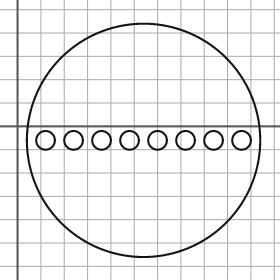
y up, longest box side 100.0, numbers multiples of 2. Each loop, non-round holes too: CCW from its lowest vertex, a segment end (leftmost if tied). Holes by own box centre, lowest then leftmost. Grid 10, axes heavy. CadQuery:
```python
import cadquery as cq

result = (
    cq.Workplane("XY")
    .moveTo(54.0, -6.0)
    .circle(50.0)
    .moveTo(12.0, -6.0)
    .circle(4.0)
    .moveTo(24.0, -6.0)
    .circle(4.0)
    .moveTo(36.0, -6.0)
    .circle(4.0)
    .moveTo(48.0, -6.0)
    .circle(4.0)
    .moveTo(60.0, -6.0)
    .circle(4.0)
    .moveTo(72.0, -6.0)
    .circle(4.0)
    .moveTo(84.0, -6.0)
    .circle(4.0)
    .moveTo(96.0, -6.0)
    .circle(4.0)
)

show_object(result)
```